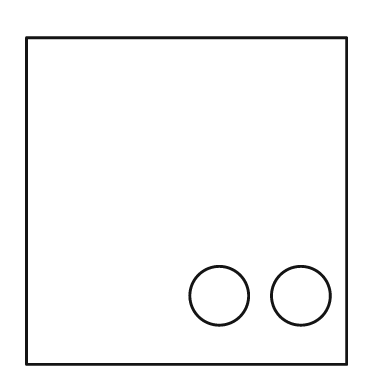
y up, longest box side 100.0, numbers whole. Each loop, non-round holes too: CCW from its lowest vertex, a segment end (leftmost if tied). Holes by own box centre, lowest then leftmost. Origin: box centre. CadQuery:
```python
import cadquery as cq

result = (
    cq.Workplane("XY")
    .moveTo(-49.0, -50.0)
    .lineTo(49.0, -50.0)
    .lineTo(49.0, 50.0)
    .lineTo(-49.0, 50.0)
    .close()
    .moveTo(10.0, -29.0)
    .circle(9.0)
    .moveTo(35.0, -29.0)
    .circle(9.0)
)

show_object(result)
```